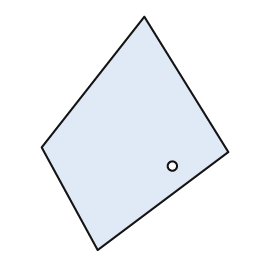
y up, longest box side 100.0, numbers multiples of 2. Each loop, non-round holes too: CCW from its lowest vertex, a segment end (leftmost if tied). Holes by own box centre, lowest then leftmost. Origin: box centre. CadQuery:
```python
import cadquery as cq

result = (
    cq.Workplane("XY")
    .moveTo(-16.0, -50.0)
    .lineTo(40.0, -8.0)
    .lineTo(4.0, 50.0)
    .lineTo(-40.0, -6.0)
    .close()
    .moveTo(16.0, -14.0)
    .circle(2.0)
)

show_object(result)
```